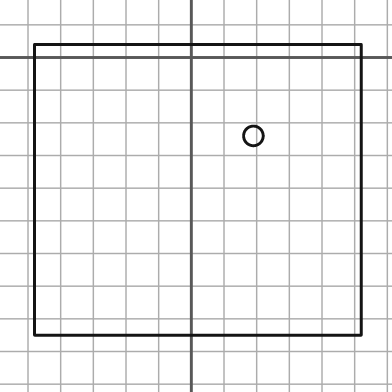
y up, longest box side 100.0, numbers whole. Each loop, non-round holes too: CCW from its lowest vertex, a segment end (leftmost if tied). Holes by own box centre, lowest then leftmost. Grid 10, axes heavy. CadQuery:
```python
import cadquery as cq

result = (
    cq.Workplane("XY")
    .moveTo(-48.0, -85.0)
    .lineTo(52.0, -85.0)
    .lineTo(52.0, 4.0)
    .lineTo(-48.0, 4.0)
    .close()
    .moveTo(19.0, -24.0)
    .circle(3.0)
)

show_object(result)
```